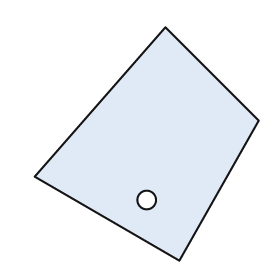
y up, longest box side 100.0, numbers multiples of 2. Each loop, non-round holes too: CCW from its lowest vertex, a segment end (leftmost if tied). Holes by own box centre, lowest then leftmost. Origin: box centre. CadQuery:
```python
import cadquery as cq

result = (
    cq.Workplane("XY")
    .moveTo(14.0, -50.0)
    .lineTo(48.0, 10.0)
    .lineTo(8.0, 50.0)
    .lineTo(-48.0, -14.0)
    .close()
    .moveTo(0.0, -24.0)
    .circle(4.0)
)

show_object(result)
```